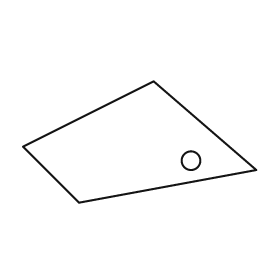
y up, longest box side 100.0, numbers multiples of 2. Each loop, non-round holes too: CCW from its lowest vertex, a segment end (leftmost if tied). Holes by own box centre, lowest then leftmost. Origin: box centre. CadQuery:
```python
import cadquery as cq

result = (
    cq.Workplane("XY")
    .moveTo(-26.0, -26.0)
    .lineTo(50.0, -12.0)
    .lineTo(6.0, 26.0)
    .lineTo(-50.0, -2.0)
    .close()
    .moveTo(22.0, -8.0)
    .circle(4.0)
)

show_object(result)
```